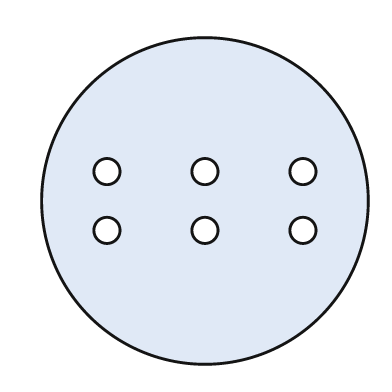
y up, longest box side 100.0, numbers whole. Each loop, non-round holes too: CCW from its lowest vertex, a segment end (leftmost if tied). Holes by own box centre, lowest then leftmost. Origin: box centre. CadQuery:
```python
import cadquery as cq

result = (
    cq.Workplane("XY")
    .moveTo(0.0, 0.0)
    .circle(50.0)
    .moveTo(-30.0, -9.0)
    .circle(4.0)
    .moveTo(0.0, -9.0)
    .circle(4.0)
    .moveTo(30.0, -9.0)
    .circle(4.0)
    .moveTo(-30.0, 9.0)
    .circle(4.0)
    .moveTo(0.0, 9.0)
    .circle(4.0)
    .moveTo(30.0, 9.0)
    .circle(4.0)
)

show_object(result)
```